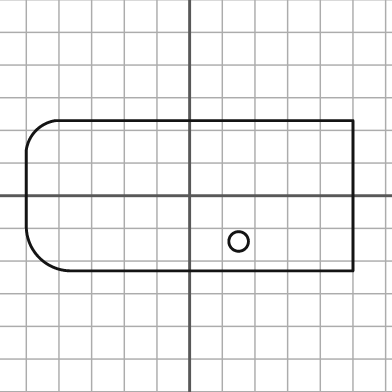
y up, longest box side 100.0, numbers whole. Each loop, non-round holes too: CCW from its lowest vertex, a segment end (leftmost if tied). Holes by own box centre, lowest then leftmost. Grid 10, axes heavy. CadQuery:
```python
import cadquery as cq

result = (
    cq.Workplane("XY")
    .moveTo(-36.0, -23.0)
    .lineTo(50.0, -23.0)
    .lineTo(50.0, 23.0)
    .lineTo(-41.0, 23.0)
    .threePointArc((-47.0, 20.0), (-50.0, 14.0))
    .lineTo(-50.0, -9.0)
    .threePointArc((-46.0, -19.0), (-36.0, -23.0))
    .close()
    .moveTo(15.0, -14.0)
    .circle(3.0)
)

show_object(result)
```